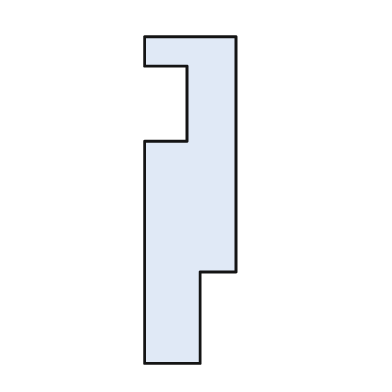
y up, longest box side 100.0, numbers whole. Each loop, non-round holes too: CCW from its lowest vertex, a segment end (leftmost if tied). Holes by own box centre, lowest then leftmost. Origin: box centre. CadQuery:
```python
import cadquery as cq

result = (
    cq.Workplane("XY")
    .moveTo(-14.0, -50.0)
    .lineTo(3.0, -50.0)
    .lineTo(3.0, -22.0)
    .lineTo(14.0, -22.0)
    .lineTo(14.0, 50.0)
    .lineTo(-14.0, 50.0)
    .lineTo(-14.0, 41.0)
    .lineTo(-1.0, 41.0)
    .lineTo(-1.0, 18.0)
    .lineTo(-14.0, 18.0)
    .close()
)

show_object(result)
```